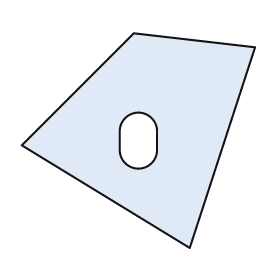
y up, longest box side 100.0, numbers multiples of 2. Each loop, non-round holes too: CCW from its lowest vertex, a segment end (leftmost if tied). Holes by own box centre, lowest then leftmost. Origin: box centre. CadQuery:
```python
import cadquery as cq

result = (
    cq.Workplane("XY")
    .moveTo(22.0, -46.0)
    .lineTo(50.0, 40.0)
    .lineTo(-2.0, 46.0)
    .lineTo(-50.0, -2.0)
    .close()
    .moveTo(-8.0, -4.0)
    .threePointArc((0.0, -12.0), (8.0, -4.0))
    .lineTo(8.0, 4.0)
    .threePointArc((0.0, 12.0), (-8.0, 4.0))
    .close()
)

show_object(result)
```